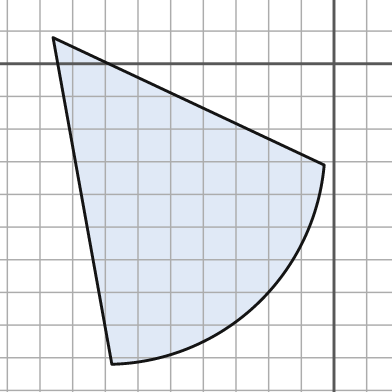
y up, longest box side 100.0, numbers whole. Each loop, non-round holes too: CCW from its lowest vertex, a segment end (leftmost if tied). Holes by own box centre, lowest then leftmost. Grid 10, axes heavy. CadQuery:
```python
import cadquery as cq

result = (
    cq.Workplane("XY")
    .moveTo(-68.0, -92.0)
    .threePointArc((-24.0, -74.0), (-3.0, -31.0))
    .lineTo(-86.0, 8.0)
    .close()
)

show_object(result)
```